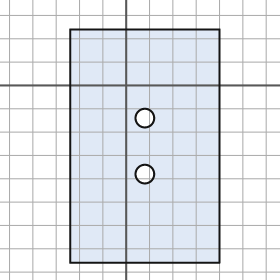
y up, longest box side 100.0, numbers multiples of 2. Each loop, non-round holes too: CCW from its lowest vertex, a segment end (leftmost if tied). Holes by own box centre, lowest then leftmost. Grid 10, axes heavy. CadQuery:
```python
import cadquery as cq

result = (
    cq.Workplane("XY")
    .moveTo(-24.0, -76.0)
    .lineTo(40.0, -76.0)
    .lineTo(40.0, 24.0)
    .lineTo(-24.0, 24.0)
    .close()
    .moveTo(8.0, -38.0)
    .circle(4.0)
    .moveTo(8.0, -14.0)
    .circle(4.0)
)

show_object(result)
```